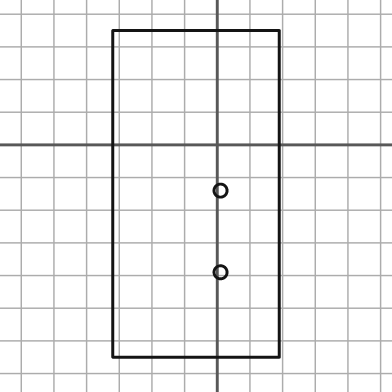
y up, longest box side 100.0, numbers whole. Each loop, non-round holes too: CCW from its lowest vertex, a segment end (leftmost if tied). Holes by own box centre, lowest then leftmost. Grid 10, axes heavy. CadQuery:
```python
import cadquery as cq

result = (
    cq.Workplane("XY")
    .moveTo(-32.0, -65.0)
    .lineTo(19.0, -65.0)
    .lineTo(19.0, 35.0)
    .lineTo(-32.0, 35.0)
    .close()
    .moveTo(1.0, -39.0)
    .circle(2.0)
    .moveTo(1.0, -14.0)
    .circle(2.0)
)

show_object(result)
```